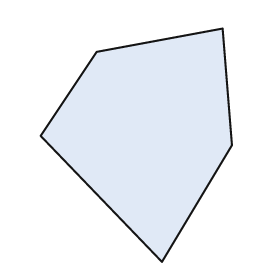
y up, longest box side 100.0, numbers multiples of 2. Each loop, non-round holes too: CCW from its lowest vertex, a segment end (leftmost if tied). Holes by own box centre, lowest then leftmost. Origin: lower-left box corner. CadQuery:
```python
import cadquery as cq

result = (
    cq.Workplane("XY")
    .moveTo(52.0, 0.0)
    .lineTo(82.0, 50.0)
    .lineTo(78.0, 100.0)
    .lineTo(24.0, 90.0)
    .lineTo(0.0, 54.0)
    .close()
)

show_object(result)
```